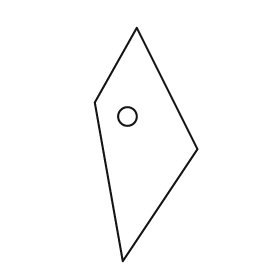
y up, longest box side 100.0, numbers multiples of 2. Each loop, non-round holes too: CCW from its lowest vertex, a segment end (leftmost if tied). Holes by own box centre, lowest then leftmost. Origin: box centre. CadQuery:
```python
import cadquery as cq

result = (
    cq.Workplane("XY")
    .moveTo(-10.0, -50.0)
    .lineTo(22.0, -2.0)
    .lineTo(-4.0, 50.0)
    .lineTo(-22.0, 18.0)
    .close()
    .moveTo(-8.0, 12.0)
    .circle(4.0)
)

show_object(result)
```